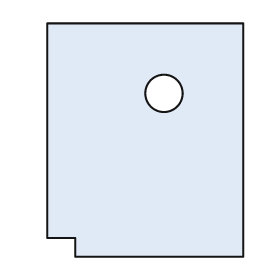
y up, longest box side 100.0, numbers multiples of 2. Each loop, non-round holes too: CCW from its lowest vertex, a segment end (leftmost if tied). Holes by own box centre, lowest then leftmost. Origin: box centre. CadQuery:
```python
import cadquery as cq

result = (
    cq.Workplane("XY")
    .moveTo(-30.0, -50.0)
    .lineTo(42.0, -50.0)
    .lineTo(42.0, 50.0)
    .lineTo(-42.0, 50.0)
    .lineTo(-42.0, -42.0)
    .lineTo(-30.0, -42.0)
    .close()
    .moveTo(8.0, 20.0)
    .circle(8.0)
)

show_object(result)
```